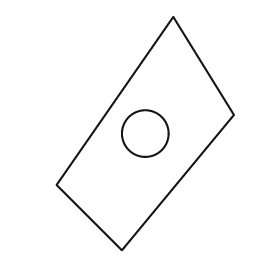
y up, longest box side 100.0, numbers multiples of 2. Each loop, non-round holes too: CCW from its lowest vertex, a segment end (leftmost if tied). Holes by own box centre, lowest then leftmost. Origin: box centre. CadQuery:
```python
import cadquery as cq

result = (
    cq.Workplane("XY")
    .moveTo(-10.0, -50.0)
    .lineTo(38.0, 8.0)
    .lineTo(12.0, 50.0)
    .lineTo(-38.0, -22.0)
    .close()
    .moveTo(0.0, 0.0)
    .circle(10.0)
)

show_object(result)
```